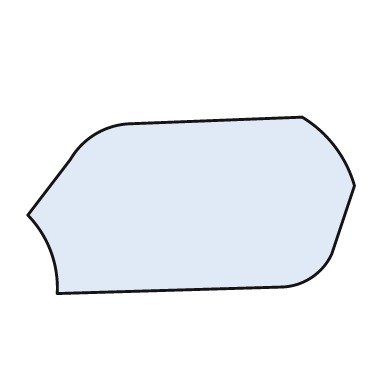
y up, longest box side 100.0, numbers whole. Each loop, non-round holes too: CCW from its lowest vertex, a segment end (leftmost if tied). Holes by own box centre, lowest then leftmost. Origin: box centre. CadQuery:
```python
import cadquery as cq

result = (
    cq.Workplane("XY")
    .moveTo(-41.0, -27.0)
    .lineTo(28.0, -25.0)
    .threePointArc((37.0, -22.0), (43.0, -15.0))
    .lineTo(50.0, 6.0)
    .threePointArc((44.0, 18.0), (34.0, 27.0))
    .lineTo(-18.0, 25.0)
    .threePointArc((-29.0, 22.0), (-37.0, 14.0))
    .lineTo(-50.0, -3.0)
    .threePointArc((-43.0, -14.0), (-41.0, -27.0))
    .close()
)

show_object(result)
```